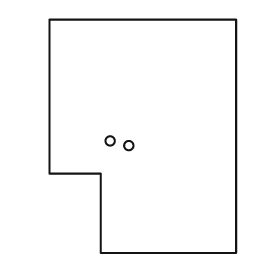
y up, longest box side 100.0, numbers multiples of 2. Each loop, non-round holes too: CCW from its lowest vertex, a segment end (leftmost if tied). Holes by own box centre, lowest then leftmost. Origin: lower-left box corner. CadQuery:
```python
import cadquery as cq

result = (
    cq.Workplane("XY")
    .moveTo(22.0, 0.0)
    .lineTo(80.0, 0.0)
    .lineTo(80.0, 100.0)
    .lineTo(0.0, 100.0)
    .lineTo(0.0, 34.0)
    .lineTo(22.0, 34.0)
    .close()
    .moveTo(34.0, 46.0)
    .circle(2.0)
    .moveTo(26.0, 48.0)
    .circle(2.0)
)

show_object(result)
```